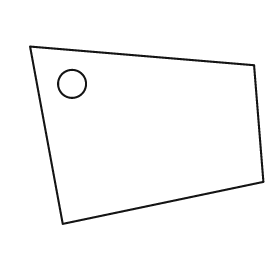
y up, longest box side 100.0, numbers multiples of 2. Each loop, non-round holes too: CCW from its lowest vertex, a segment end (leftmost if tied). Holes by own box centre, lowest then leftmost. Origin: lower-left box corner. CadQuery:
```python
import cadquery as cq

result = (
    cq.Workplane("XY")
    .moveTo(14.0, 0.0)
    .lineTo(100.0, 18.0)
    .lineTo(96.0, 68.0)
    .lineTo(0.0, 76.0)
    .close()
    .moveTo(18.0, 60.0)
    .circle(6.0)
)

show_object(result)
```